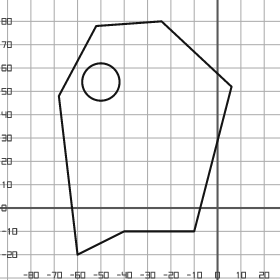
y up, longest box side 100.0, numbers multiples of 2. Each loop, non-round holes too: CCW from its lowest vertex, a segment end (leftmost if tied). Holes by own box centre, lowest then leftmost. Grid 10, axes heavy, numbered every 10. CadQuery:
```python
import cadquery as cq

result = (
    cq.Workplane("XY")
    .moveTo(-60.0, -20.0)
    .lineTo(-40.0, -10.0)
    .lineTo(-10.0, -10.0)
    .lineTo(6.0, 52.0)
    .lineTo(-24.0, 80.0)
    .lineTo(-52.0, 78.0)
    .lineTo(-68.0, 48.0)
    .close()
    .moveTo(-50.0, 54.0)
    .circle(8.0)
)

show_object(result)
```